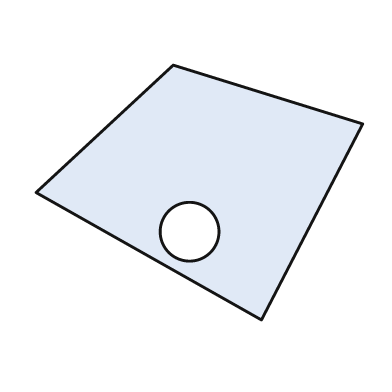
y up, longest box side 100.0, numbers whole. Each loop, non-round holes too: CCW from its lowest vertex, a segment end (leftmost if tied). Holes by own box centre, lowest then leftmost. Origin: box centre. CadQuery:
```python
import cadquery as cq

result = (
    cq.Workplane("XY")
    .moveTo(19.0, -39.0)
    .lineTo(50.0, 21.0)
    .lineTo(-8.0, 39.0)
    .lineTo(-50.0, 0.0)
    .close()
    .moveTo(-3.0, -12.0)
    .circle(9.0)
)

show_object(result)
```